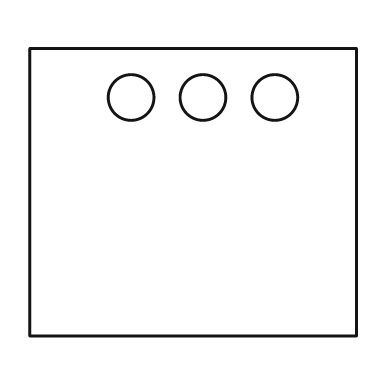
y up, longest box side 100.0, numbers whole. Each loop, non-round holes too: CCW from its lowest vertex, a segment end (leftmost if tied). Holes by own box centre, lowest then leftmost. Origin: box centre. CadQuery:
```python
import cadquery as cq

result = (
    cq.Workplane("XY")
    .moveTo(-50.0, -44.0)
    .lineTo(50.0, -44.0)
    .lineTo(50.0, 44.0)
    .lineTo(-50.0, 44.0)
    .close()
    .moveTo(-19.0, 29.0)
    .circle(7.0)
    .moveTo(3.0, 29.0)
    .circle(7.0)
    .moveTo(25.0, 29.0)
    .circle(7.0)
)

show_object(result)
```